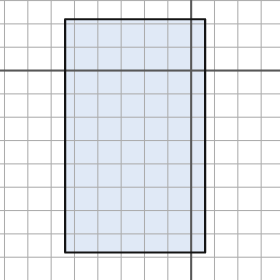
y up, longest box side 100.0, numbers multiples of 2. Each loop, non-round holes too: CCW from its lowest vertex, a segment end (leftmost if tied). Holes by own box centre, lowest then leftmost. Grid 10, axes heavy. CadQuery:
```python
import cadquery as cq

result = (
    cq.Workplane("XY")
    .moveTo(-54.0, -78.0)
    .lineTo(6.0, -78.0)
    .lineTo(6.0, 22.0)
    .lineTo(-54.0, 22.0)
    .close()
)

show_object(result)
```